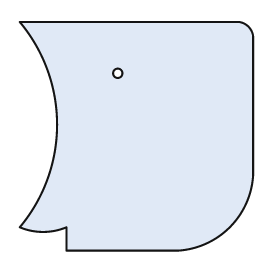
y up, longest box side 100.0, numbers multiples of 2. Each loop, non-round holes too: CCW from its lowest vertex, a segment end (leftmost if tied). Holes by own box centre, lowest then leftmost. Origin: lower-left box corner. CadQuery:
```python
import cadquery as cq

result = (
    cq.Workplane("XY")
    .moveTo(20.0, 0.0)
    .lineTo(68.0, 0.0)
    .threePointArc((90.0, 10.0), (100.0, 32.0))
    .lineTo(100.0, 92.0)
    .threePointArc((98.0, 96.0), (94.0, 98.0))
    .lineTo(0.0, 98.0)
    .threePointArc((16.0, 54.0), (0.0, 10.0))
    .threePointArc((10.0, 8.0), (20.0, 10.0))
    .close()
    .moveTo(42.0, 76.0)
    .circle(2.0)
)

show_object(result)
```